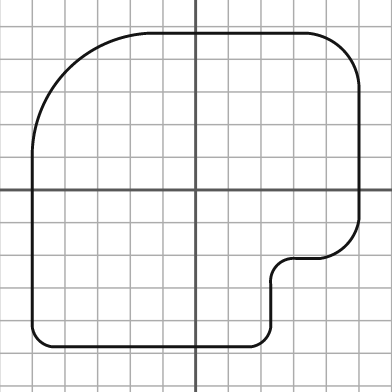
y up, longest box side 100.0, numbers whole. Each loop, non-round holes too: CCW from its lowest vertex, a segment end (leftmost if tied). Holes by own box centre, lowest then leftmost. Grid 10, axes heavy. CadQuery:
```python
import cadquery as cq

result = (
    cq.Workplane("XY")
    .moveTo(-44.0, -48.0)
    .lineTo(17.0, -48.0)
    .threePointArc((21.0, -46.0), (23.0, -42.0))
    .lineTo(23.0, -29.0)
    .threePointArc((25.0, -23.0), (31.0, -21.0))
    .lineTo(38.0, -21.0)
    .threePointArc((46.0, -17.0), (50.0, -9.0))
    .lineTo(50.0, 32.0)
    .threePointArc((45.0, 43.0), (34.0, 48.0))
    .lineTo(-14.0, 48.0)
    .threePointArc((-39.0, 37.0), (-50.0, 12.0))
    .lineTo(-50.0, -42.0)
    .threePointArc((-48.0, -46.0), (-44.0, -48.0))
    .close()
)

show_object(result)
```